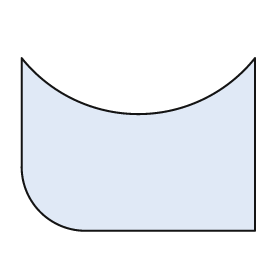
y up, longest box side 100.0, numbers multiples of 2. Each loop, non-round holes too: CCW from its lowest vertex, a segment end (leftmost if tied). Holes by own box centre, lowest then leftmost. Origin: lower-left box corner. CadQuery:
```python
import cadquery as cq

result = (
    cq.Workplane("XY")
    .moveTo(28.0, 0.0)
    .lineTo(100.0, 0.0)
    .lineTo(100.0, 74.0)
    .threePointArc((50.0, 50.0), (0.0, 74.0))
    .lineTo(0.0, 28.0)
    .threePointArc((8.0, 8.0), (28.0, 0.0))
    .close()
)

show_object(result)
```